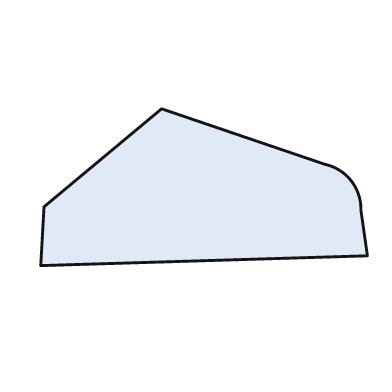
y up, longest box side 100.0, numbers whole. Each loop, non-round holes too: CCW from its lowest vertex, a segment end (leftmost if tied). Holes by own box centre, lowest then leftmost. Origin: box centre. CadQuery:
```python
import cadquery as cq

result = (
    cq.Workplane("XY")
    .moveTo(-50.0, -24.0)
    .lineTo(50.0, -21.0)
    .lineTo(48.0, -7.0)
    .threePointArc((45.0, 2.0), (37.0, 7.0))
    .lineTo(-13.0, 24.0)
    .lineTo(-49.0, -6.0)
    .close()
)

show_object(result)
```